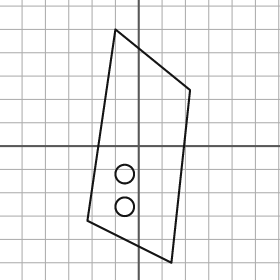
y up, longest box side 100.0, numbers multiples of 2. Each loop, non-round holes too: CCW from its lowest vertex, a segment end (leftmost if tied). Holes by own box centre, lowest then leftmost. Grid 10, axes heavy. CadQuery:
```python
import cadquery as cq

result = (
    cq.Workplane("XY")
    .moveTo(14.0, -50.0)
    .lineTo(22.0, 24.0)
    .lineTo(-10.0, 50.0)
    .lineTo(-22.0, -32.0)
    .close()
    .moveTo(-6.0, -26.0)
    .circle(4.0)
    .moveTo(-6.0, -12.0)
    .circle(4.0)
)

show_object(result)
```